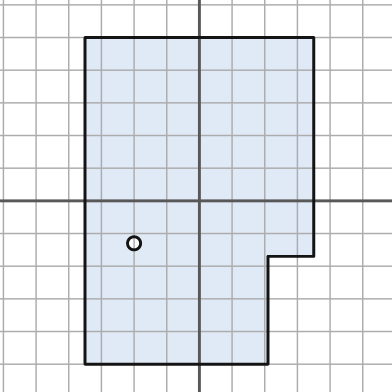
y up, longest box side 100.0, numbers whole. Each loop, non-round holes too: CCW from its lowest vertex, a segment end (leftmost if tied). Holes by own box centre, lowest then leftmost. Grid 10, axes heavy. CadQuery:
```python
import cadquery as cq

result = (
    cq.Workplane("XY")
    .moveTo(-35.0, -50.0)
    .lineTo(21.0, -50.0)
    .lineTo(21.0, -17.0)
    .lineTo(35.0, -17.0)
    .lineTo(35.0, 50.0)
    .lineTo(-35.0, 50.0)
    .close()
    .moveTo(-20.0, -13.0)
    .circle(2.0)
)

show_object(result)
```